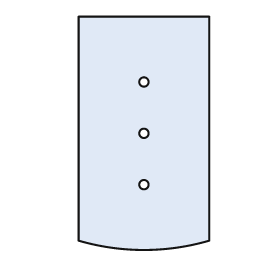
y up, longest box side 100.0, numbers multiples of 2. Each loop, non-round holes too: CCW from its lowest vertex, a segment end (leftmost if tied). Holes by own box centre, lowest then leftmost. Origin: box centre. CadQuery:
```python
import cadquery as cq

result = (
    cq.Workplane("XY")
    .moveTo(-28.0, -46.0)
    .threePointArc((0.0, -50.0), (28.0, -46.0))
    .lineTo(28.0, 50.0)
    .lineTo(-28.0, 50.0)
    .close()
    .moveTo(0.0, -22.0)
    .circle(2.0)
    .moveTo(0.0, 0.0)
    .circle(2.0)
    .moveTo(0.0, 22.0)
    .circle(2.0)
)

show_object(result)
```